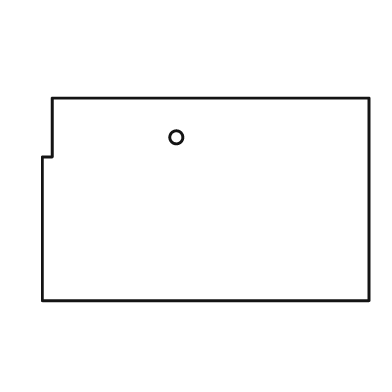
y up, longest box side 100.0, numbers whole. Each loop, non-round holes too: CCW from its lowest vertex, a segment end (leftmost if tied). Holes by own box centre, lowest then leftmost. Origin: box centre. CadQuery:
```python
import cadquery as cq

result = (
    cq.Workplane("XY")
    .moveTo(-50.0, -31.0)
    .lineTo(50.0, -31.0)
    .lineTo(50.0, 31.0)
    .lineTo(-47.0, 31.0)
    .lineTo(-47.0, 13.0)
    .lineTo(-50.0, 13.0)
    .close()
    .moveTo(-9.0, 19.0)
    .circle(2.0)
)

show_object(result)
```